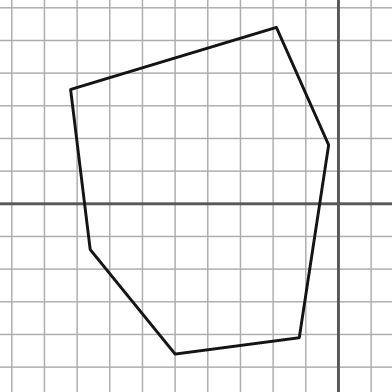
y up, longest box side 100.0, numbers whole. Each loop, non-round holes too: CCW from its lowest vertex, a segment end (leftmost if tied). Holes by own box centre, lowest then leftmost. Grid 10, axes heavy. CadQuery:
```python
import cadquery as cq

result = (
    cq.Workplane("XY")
    .moveTo(-50.0, -46.0)
    .lineTo(-12.0, -41.0)
    .lineTo(-3.0, 18.0)
    .lineTo(-19.0, 54.0)
    .lineTo(-82.0, 35.0)
    .lineTo(-76.0, -14.0)
    .close()
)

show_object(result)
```